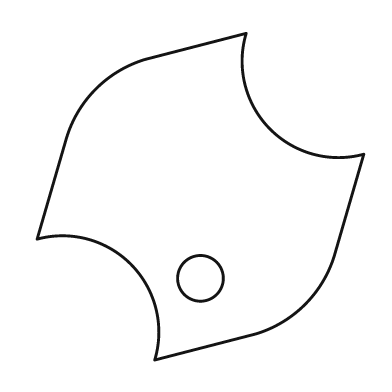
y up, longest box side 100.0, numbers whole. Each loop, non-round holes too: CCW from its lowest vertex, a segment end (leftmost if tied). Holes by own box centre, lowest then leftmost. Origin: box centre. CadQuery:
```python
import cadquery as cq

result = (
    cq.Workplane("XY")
    .moveTo(-14.0, -50.0)
    .lineTo(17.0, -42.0)
    .threePointArc((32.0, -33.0), (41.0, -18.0))
    .lineTo(50.0, 13.0)
    .threePointArc((21.0, 21.0), (14.0, 50.0))
    .lineTo(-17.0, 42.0)
    .threePointArc((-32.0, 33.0), (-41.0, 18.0))
    .lineTo(-50.0, -13.0)
    .threePointArc((-21.0, -21.0), (-14.0, -50.0))
    .close()
    .moveTo(0.0, -25.0)
    .circle(7.0)
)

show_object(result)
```